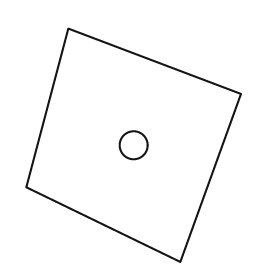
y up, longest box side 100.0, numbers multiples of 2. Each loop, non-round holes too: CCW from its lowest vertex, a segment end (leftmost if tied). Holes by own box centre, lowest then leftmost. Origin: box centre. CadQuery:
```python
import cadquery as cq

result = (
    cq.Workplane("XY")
    .moveTo(20.0, -50.0)
    .lineTo(46.0, 22.0)
    .lineTo(-28.0, 50.0)
    .lineTo(-46.0, -18.0)
    .close()
    .moveTo(0.0, 0.0)
    .circle(6.0)
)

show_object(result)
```